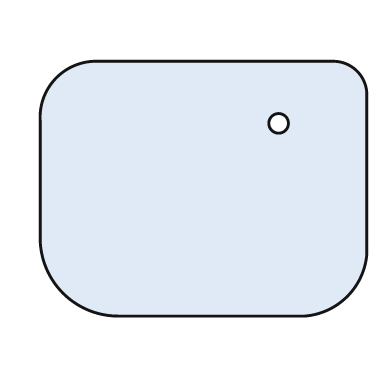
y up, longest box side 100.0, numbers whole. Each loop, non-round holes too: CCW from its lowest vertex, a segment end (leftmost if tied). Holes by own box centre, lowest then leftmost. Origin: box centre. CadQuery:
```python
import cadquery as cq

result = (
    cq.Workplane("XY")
    .moveTo(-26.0, -39.0)
    .lineTo(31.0, -39.0)
    .threePointArc((44.0, -33.0), (50.0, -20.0))
    .lineTo(50.0, 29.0)
    .threePointArc((47.0, 36.0), (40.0, 39.0))
    .lineTo(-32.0, 39.0)
    .threePointArc((-45.0, 34.0), (-50.0, 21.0))
    .lineTo(-50.0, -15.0)
    .threePointArc((-43.0, -32.0), (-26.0, -39.0))
    .close()
    .moveTo(23.0, 20.0)
    .circle(3.0)
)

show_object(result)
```